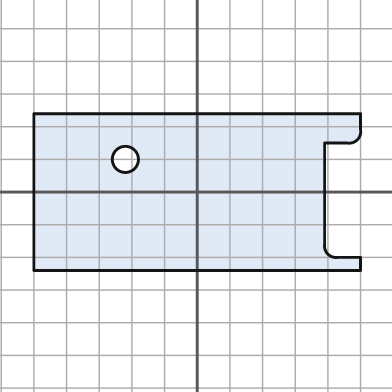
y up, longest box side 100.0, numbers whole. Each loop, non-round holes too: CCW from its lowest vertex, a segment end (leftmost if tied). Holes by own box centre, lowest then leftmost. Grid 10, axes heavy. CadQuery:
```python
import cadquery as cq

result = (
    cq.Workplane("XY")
    .moveTo(-50.0, -24.0)
    .lineTo(50.0, -24.0)
    .lineTo(50.0, -20.0)
    .lineTo(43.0, -20.0)
    .threePointArc((40.0, -19.0), (39.0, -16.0))
    .lineTo(39.0, 15.0)
    .lineTo(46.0, 15.0)
    .threePointArc((49.0, 16.0), (50.0, 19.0))
    .lineTo(50.0, 24.0)
    .lineTo(-50.0, 24.0)
    .close()
    .moveTo(-22.0, 10.0)
    .circle(4.0)
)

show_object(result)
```